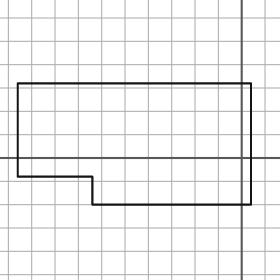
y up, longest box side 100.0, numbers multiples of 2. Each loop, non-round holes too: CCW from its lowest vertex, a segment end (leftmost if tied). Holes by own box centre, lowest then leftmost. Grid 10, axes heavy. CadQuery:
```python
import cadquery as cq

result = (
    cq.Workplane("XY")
    .moveTo(-64.0, -20.0)
    .lineTo(4.0, -20.0)
    .lineTo(4.0, 32.0)
    .lineTo(-96.0, 32.0)
    .lineTo(-96.0, -8.0)
    .lineTo(-64.0, -8.0)
    .close()
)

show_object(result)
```